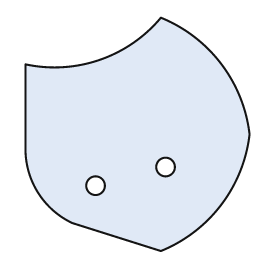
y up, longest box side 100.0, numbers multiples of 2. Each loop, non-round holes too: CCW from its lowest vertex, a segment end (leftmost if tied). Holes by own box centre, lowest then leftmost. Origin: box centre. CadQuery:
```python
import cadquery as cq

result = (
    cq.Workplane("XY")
    .moveTo(10.0, -50.0)
    .threePointArc((36.0, -30.0), (48.0, 0.0))
    .threePointArc((36.0, 30.0), (10.0, 50.0))
    .threePointArc((-16.0, 32.0), (-48.0, 30.0))
    .lineTo(-48.0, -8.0)
    .threePointArc((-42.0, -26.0), (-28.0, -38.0))
    .close()
    .moveTo(-18.0, -22.0)
    .circle(4.0)
    .moveTo(12.0, -14.0)
    .circle(4.0)
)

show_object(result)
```